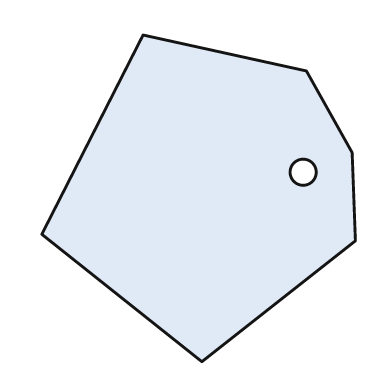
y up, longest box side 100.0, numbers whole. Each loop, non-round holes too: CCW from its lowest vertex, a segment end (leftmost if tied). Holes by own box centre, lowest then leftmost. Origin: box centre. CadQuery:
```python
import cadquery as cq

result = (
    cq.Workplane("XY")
    .moveTo(1.0, -50.0)
    .lineTo(48.0, -13.0)
    .lineTo(47.0, 14.0)
    .lineTo(33.0, 39.0)
    .lineTo(-17.0, 50.0)
    .lineTo(-48.0, -11.0)
    .close()
    .moveTo(32.0, 8.0)
    .circle(4.0)
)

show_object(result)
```